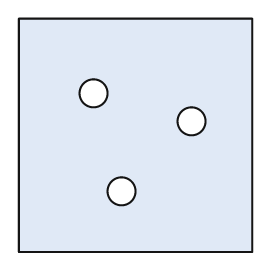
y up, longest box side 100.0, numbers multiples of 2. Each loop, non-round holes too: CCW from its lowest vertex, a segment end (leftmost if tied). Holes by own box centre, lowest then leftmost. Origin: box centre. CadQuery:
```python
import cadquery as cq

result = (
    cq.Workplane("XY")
    .moveTo(-50.0, -50.0)
    .lineTo(50.0, -50.0)
    .lineTo(50.0, 50.0)
    .lineTo(-50.0, 50.0)
    .close()
    .moveTo(-6.0, -24.0)
    .circle(6.0)
    .moveTo(24.0, 6.0)
    .circle(6.0)
    .moveTo(-18.0, 18.0)
    .circle(6.0)
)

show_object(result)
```